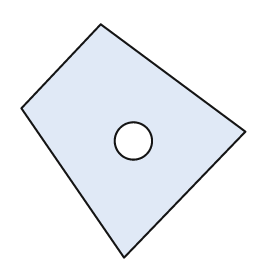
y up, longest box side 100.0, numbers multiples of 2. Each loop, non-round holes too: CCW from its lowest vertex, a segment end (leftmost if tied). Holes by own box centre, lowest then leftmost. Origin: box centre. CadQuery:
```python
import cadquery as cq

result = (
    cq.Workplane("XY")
    .moveTo(-4.0, -50.0)
    .lineTo(48.0, 4.0)
    .lineTo(-14.0, 50.0)
    .lineTo(-48.0, 14.0)
    .close()
    .moveTo(0.0, 0.0)
    .circle(8.0)
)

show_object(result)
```